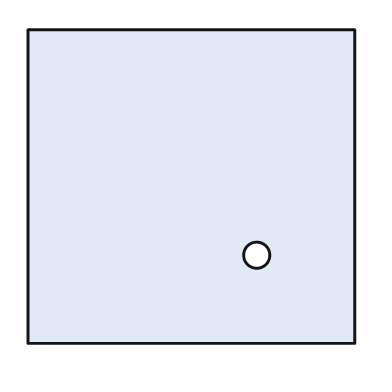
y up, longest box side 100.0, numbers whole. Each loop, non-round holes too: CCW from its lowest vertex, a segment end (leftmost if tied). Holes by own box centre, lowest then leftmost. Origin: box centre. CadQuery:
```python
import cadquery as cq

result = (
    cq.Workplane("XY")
    .moveTo(-50.0, -48.0)
    .lineTo(50.0, -48.0)
    .lineTo(50.0, 48.0)
    .lineTo(-50.0, 48.0)
    .close()
    .moveTo(20.0, -21.0)
    .circle(4.0)
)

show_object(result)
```